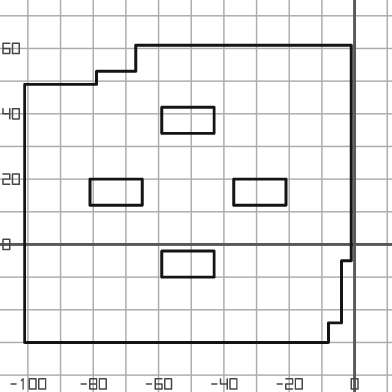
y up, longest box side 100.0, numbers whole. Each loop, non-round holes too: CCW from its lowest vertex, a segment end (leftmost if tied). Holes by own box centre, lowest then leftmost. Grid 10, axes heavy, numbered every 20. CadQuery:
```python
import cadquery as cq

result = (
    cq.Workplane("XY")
    .moveTo(-101.0, -30.0)
    .lineTo(-8.0, -30.0)
    .lineTo(-8.0, -24.0)
    .lineTo(-4.0, -24.0)
    .lineTo(-4.0, -5.0)
    .lineTo(-1.0, -5.0)
    .lineTo(-1.0, 61.0)
    .lineTo(-67.0, 61.0)
    .lineTo(-67.0, 53.0)
    .lineTo(-79.0, 53.0)
    .lineTo(-79.0, 49.0)
    .lineTo(-101.0, 49.0)
    .close()
    .moveTo(-59.0, -10.0)
    .lineTo(-43.0, -10.0)
    .lineTo(-43.0, -2.0)
    .lineTo(-59.0, -2.0)
    .close()
    .moveTo(-81.0, 12.0)
    .lineTo(-65.0, 12.0)
    .lineTo(-65.0, 20.0)
    .lineTo(-81.0, 20.0)
    .close()
    .moveTo(-37.0, 12.0)
    .lineTo(-21.0, 12.0)
    .lineTo(-21.0, 20.0)
    .lineTo(-37.0, 20.0)
    .close()
    .moveTo(-59.0, 34.0)
    .lineTo(-43.0, 34.0)
    .lineTo(-43.0, 42.0)
    .lineTo(-59.0, 42.0)
    .close()
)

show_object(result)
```